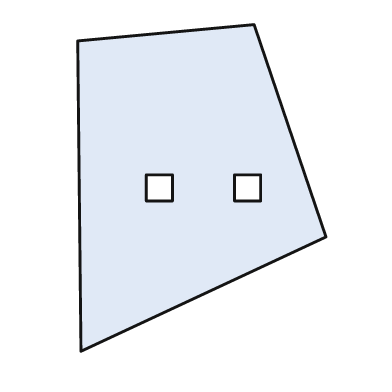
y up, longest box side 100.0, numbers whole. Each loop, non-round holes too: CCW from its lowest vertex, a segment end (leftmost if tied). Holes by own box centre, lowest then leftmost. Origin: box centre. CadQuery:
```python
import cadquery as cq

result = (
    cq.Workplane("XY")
    .moveTo(-37.0, -50.0)
    .lineTo(38.0, -15.0)
    .lineTo(16.0, 50.0)
    .lineTo(-38.0, 45.0)
    .close()
    .moveTo(-17.0, -4.0)
    .lineTo(-9.0, -4.0)
    .lineTo(-9.0, 4.0)
    .lineTo(-17.0, 4.0)
    .close()
    .moveTo(10.0, -4.0)
    .lineTo(18.0, -4.0)
    .lineTo(18.0, 4.0)
    .lineTo(10.0, 4.0)
    .close()
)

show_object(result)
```